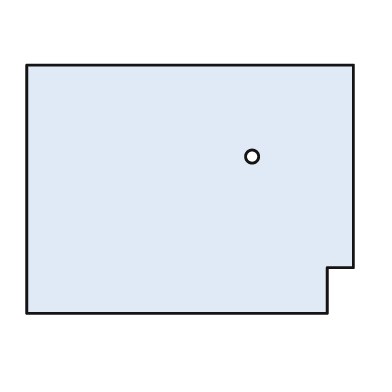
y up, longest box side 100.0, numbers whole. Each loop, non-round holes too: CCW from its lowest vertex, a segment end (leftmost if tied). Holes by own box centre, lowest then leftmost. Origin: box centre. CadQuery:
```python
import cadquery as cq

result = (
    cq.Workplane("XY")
    .moveTo(-50.0, -38.0)
    .lineTo(42.0, -38.0)
    .lineTo(42.0, -24.0)
    .lineTo(50.0, -24.0)
    .lineTo(50.0, 38.0)
    .lineTo(-50.0, 38.0)
    .close()
    .moveTo(19.0, 10.0)
    .circle(2.0)
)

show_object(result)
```